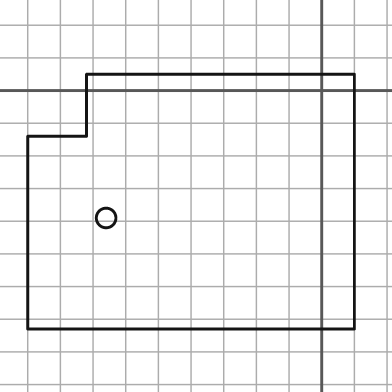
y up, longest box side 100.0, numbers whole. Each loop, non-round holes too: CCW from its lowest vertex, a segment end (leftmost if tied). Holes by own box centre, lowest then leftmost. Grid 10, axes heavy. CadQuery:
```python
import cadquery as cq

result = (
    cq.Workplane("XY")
    .moveTo(-90.0, -73.0)
    .lineTo(10.0, -73.0)
    .lineTo(10.0, 5.0)
    .lineTo(-72.0, 5.0)
    .lineTo(-72.0, -14.0)
    .lineTo(-90.0, -14.0)
    .close()
    .moveTo(-66.0, -39.0)
    .circle(3.0)
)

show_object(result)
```